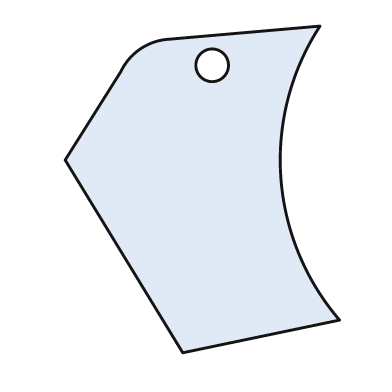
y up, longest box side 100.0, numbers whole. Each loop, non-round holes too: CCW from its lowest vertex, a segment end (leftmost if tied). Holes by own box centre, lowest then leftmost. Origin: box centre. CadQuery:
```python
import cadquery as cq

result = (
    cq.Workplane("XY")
    .moveTo(-6.0, -50.0)
    .lineTo(42.0, -40.0)
    .threePointArc((24.0, 4.0), (36.0, 50.0))
    .lineTo(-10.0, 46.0)
    .threePointArc((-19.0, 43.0), (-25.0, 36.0))
    .lineTo(-42.0, 9.0)
    .close()
    .moveTo(3.0, 38.0)
    .circle(5.0)
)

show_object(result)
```